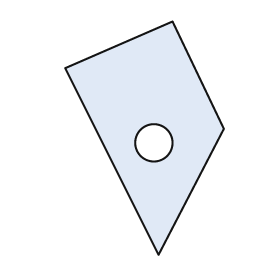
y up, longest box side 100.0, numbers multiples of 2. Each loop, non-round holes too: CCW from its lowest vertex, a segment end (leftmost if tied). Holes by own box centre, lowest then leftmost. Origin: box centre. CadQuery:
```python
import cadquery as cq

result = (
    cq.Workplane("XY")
    .moveTo(6.0, -50.0)
    .lineTo(34.0, 4.0)
    .lineTo(12.0, 50.0)
    .lineTo(-34.0, 30.0)
    .close()
    .moveTo(4.0, -2.0)
    .circle(8.0)
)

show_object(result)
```